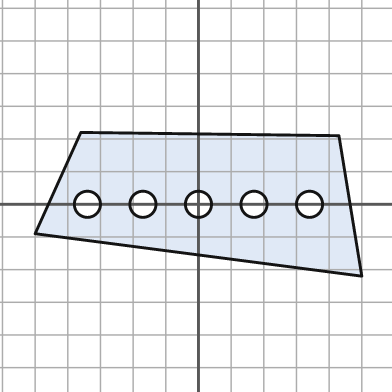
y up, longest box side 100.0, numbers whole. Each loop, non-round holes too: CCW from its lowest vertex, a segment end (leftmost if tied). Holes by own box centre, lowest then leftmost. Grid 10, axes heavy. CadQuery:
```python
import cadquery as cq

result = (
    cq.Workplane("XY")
    .moveTo(50.0, -22.0)
    .lineTo(43.0, 21.0)
    .lineTo(-36.0, 22.0)
    .lineTo(-50.0, -9.0)
    .close()
    .moveTo(-34.0, 0.0)
    .circle(4.0)
    .moveTo(-17.0, 0.0)
    .circle(4.0)
    .moveTo(0.0, 0.0)
    .circle(4.0)
    .moveTo(17.0, 0.0)
    .circle(4.0)
    .moveTo(34.0, 0.0)
    .circle(4.0)
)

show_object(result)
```